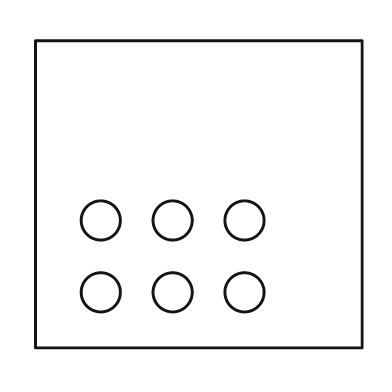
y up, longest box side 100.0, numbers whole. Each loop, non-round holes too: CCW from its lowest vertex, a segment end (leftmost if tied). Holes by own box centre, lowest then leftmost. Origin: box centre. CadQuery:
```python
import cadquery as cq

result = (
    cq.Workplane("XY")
    .moveTo(-50.0, -47.0)
    .lineTo(50.0, -47.0)
    .lineTo(50.0, 47.0)
    .lineTo(-50.0, 47.0)
    .close()
    .moveTo(-30.0, -30.0)
    .circle(6.0)
    .moveTo(-8.0, -30.0)
    .circle(6.0)
    .moveTo(14.0, -30.0)
    .circle(6.0)
    .moveTo(-30.0, -8.0)
    .circle(6.0)
    .moveTo(-8.0, -8.0)
    .circle(6.0)
    .moveTo(14.0, -8.0)
    .circle(6.0)
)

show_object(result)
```